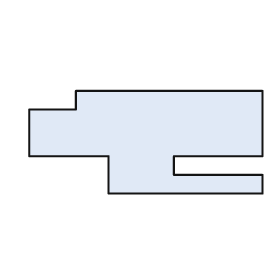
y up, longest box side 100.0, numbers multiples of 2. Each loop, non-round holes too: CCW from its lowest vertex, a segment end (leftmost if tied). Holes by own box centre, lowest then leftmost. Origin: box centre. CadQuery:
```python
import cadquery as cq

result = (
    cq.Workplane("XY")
    .moveTo(-16.0, -22.0)
    .lineTo(50.0, -22.0)
    .lineTo(50.0, -14.0)
    .lineTo(12.0, -14.0)
    .lineTo(12.0, -6.0)
    .lineTo(50.0, -6.0)
    .lineTo(50.0, 22.0)
    .lineTo(-30.0, 22.0)
    .lineTo(-30.0, 14.0)
    .lineTo(-50.0, 14.0)
    .lineTo(-50.0, -6.0)
    .lineTo(-16.0, -6.0)
    .close()
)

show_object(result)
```